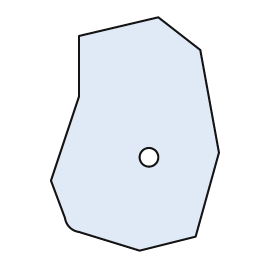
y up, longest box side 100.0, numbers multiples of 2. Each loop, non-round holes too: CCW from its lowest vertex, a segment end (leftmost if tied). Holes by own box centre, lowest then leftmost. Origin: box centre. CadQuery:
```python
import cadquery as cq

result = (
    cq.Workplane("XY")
    .moveTo(2.0, -50.0)
    .lineTo(26.0, -44.0)
    .lineTo(36.0, -8.0)
    .lineTo(28.0, 36.0)
    .lineTo(10.0, 50.0)
    .lineTo(-24.0, 42.0)
    .lineTo(-24.0, 16.0)
    .lineTo(-36.0, -20.0)
    .lineTo(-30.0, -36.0)
    .threePointArc((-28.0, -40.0), (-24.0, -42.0))
    .close()
    .moveTo(6.0, -10.0)
    .circle(4.0)
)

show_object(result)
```